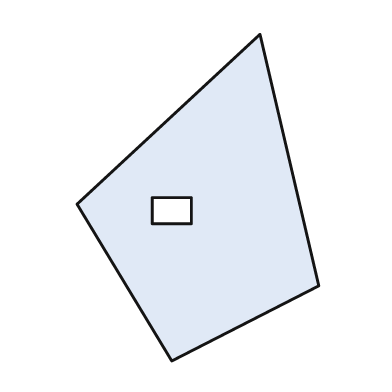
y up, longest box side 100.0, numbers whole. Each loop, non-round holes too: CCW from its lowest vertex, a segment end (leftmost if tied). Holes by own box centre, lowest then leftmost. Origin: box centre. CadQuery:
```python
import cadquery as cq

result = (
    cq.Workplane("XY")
    .moveTo(-8.0, -50.0)
    .lineTo(37.0, -27.0)
    .lineTo(19.0, 50.0)
    .lineTo(-37.0, -2.0)
    .close()
    .moveTo(-14.0, -8.0)
    .lineTo(-2.0, -8.0)
    .lineTo(-2.0, 0.0)
    .lineTo(-14.0, 0.0)
    .close()
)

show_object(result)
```